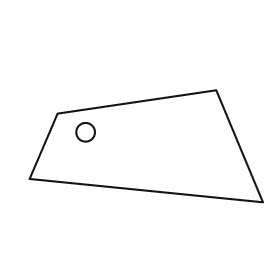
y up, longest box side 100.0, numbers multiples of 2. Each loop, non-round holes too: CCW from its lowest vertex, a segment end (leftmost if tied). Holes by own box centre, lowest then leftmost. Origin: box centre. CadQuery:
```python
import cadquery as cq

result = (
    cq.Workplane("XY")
    .moveTo(50.0, -24.0)
    .lineTo(30.0, 24.0)
    .lineTo(-38.0, 14.0)
    .lineTo(-50.0, -14.0)
    .close()
    .moveTo(-26.0, 6.0)
    .circle(4.0)
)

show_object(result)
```